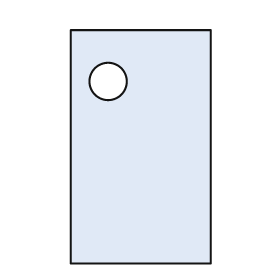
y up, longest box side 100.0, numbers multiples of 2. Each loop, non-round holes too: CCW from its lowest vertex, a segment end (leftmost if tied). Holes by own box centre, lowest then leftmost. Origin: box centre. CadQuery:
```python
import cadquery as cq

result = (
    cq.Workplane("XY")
    .moveTo(-30.0, -50.0)
    .lineTo(30.0, -50.0)
    .lineTo(30.0, 50.0)
    .lineTo(-30.0, 50.0)
    .close()
    .moveTo(-14.0, 28.0)
    .circle(8.0)
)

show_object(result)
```